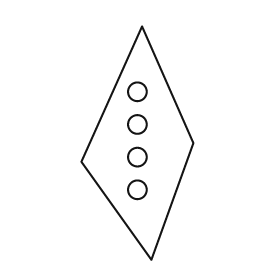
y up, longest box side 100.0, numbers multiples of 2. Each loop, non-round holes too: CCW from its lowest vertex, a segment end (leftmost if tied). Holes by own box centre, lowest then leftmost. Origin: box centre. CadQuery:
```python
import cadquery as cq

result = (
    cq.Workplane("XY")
    .moveTo(6.0, -50.0)
    .lineTo(24.0, 0.0)
    .lineTo(2.0, 50.0)
    .lineTo(-24.0, -8.0)
    .close()
    .moveTo(0.0, -20.0)
    .circle(4.0)
    .moveTo(0.0, -6.0)
    .circle(4.0)
    .moveTo(0.0, 8.0)
    .circle(4.0)
    .moveTo(0.0, 22.0)
    .circle(4.0)
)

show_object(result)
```